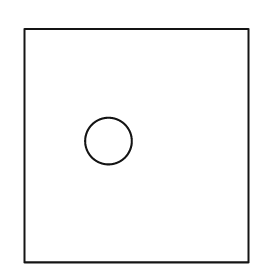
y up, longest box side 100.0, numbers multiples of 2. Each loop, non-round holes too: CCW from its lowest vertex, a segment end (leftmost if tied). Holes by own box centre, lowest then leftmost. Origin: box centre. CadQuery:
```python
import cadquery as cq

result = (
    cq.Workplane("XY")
    .moveTo(-48.0, -50.0)
    .lineTo(48.0, -50.0)
    .lineTo(48.0, 50.0)
    .lineTo(-48.0, 50.0)
    .close()
    .moveTo(-12.0, 2.0)
    .circle(10.0)
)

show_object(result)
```